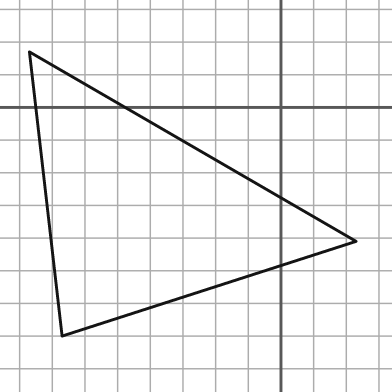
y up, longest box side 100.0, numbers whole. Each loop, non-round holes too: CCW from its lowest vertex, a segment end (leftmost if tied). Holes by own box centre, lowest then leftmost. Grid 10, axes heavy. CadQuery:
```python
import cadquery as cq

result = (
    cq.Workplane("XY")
    .moveTo(-67.0, -70.0)
    .lineTo(23.0, -41.0)
    .lineTo(-77.0, 17.0)
    .close()
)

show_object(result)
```